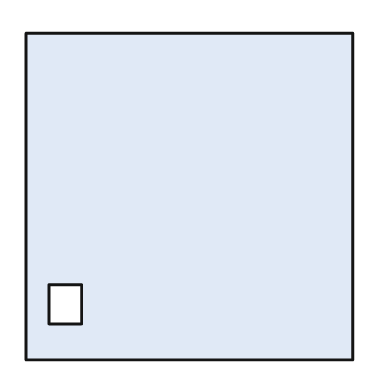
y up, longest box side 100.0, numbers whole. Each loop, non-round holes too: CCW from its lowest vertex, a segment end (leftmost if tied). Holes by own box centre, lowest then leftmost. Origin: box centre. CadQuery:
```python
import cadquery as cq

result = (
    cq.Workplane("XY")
    .moveTo(-50.0, -50.0)
    .lineTo(50.0, -50.0)
    .lineTo(50.0, 50.0)
    .lineTo(-50.0, 50.0)
    .close()
    .moveTo(-43.0, -39.0)
    .lineTo(-33.0, -39.0)
    .lineTo(-33.0, -27.0)
    .lineTo(-43.0, -27.0)
    .close()
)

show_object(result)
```